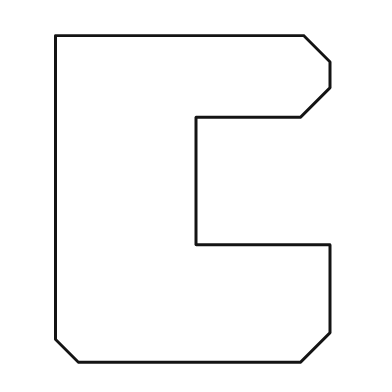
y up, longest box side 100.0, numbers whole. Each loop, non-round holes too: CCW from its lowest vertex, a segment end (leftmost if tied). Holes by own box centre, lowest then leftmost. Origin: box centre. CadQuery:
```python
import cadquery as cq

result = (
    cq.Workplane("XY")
    .moveTo(-35.0, -50.0)
    .lineTo(33.0, -50.0)
    .lineTo(42.0, -41.0)
    .lineTo(42.0, -14.0)
    .lineTo(1.0, -14.0)
    .lineTo(1.0, 25.0)
    .lineTo(33.0, 25.0)
    .lineTo(42.0, 34.0)
    .lineTo(42.0, 42.0)
    .lineTo(34.0, 50.0)
    .lineTo(-42.0, 50.0)
    .lineTo(-42.0, -43.0)
    .close()
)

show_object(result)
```